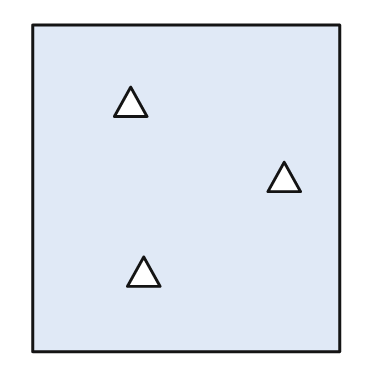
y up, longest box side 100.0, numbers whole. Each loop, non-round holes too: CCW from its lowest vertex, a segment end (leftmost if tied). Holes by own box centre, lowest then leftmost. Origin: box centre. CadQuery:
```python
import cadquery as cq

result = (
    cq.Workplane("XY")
    .moveTo(-47.0, -50.0)
    .lineTo(47.0, -50.0)
    .lineTo(47.0, 50.0)
    .lineTo(-47.0, 50.0)
    .close()
    .moveTo(-18.0, -30.0)
    .lineTo(-8.0, -30.0)
    .lineTo(-13.0, -21.0)
    .close()
    .moveTo(25.0, -1.0)
    .lineTo(35.0, -1.0)
    .lineTo(30.0, 8.0)
    .close()
    .moveTo(-22.0, 22.0)
    .lineTo(-12.0, 22.0)
    .lineTo(-17.0, 31.0)
    .close()
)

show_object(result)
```